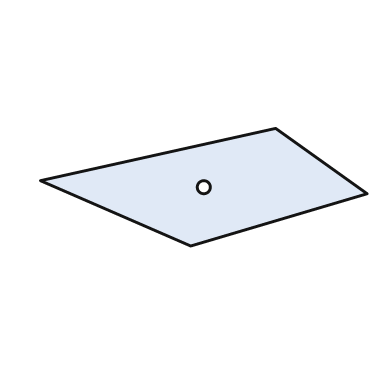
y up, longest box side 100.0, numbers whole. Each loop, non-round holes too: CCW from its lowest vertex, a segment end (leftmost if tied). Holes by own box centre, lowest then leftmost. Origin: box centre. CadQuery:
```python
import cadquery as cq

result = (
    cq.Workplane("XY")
    .moveTo(-4.0, -18.0)
    .lineTo(50.0, -2.0)
    .lineTo(22.0, 18.0)
    .lineTo(-50.0, 2.0)
    .close()
    .moveTo(0.0, 0.0)
    .circle(2.0)
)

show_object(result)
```